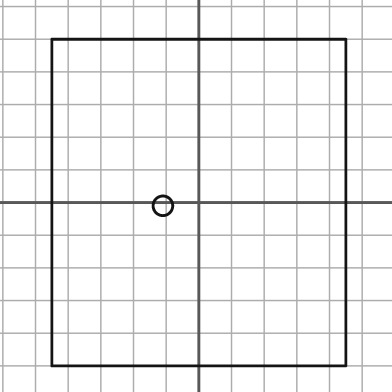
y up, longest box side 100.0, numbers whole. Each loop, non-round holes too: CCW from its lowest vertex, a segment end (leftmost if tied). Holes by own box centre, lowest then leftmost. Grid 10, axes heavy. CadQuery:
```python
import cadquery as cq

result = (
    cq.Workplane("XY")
    .moveTo(-45.0, -50.0)
    .lineTo(45.0, -50.0)
    .lineTo(45.0, 50.0)
    .lineTo(-45.0, 50.0)
    .close()
    .moveTo(-11.0, -1.0)
    .circle(3.0)
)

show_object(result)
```